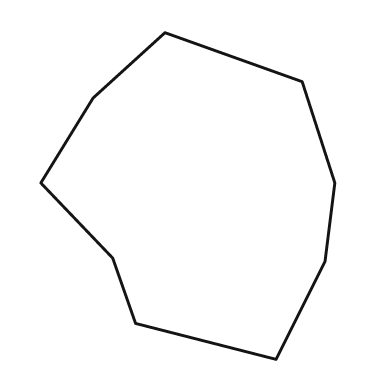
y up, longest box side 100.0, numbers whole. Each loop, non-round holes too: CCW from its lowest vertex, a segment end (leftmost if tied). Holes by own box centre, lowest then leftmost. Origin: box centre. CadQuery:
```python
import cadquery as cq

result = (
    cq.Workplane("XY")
    .moveTo(27.0, -50.0)
    .lineTo(42.0, -20.0)
    .lineTo(45.0, 4.0)
    .lineTo(35.0, 35.0)
    .lineTo(-7.0, 50.0)
    .lineTo(-29.0, 30.0)
    .lineTo(-45.0, 4.0)
    .lineTo(-23.0, -19.0)
    .lineTo(-16.0, -39.0)
    .close()
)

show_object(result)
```